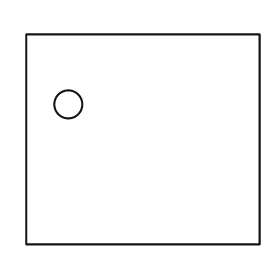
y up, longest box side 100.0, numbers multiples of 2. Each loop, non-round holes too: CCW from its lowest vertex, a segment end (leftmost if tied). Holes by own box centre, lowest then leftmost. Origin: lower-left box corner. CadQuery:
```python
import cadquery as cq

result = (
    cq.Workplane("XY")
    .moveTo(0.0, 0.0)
    .lineTo(100.0, 0.0)
    .lineTo(100.0, 90.0)
    .lineTo(0.0, 90.0)
    .close()
    .moveTo(18.0, 60.0)
    .circle(6.0)
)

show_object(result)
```